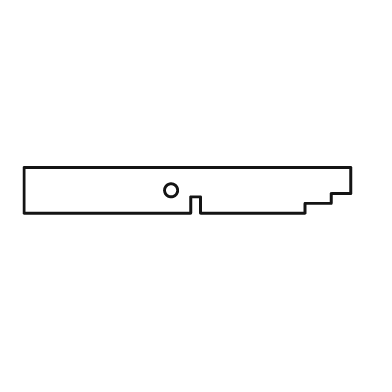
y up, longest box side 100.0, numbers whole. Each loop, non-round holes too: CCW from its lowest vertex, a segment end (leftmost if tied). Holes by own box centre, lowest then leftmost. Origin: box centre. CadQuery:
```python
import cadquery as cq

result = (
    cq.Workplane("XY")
    .moveTo(-50.0, -7.0)
    .lineTo(1.0, -7.0)
    .lineTo(1.0, -2.0)
    .lineTo(4.0, -2.0)
    .lineTo(4.0, -7.0)
    .lineTo(36.0, -7.0)
    .lineTo(36.0, -4.0)
    .lineTo(44.0, -4.0)
    .lineTo(44.0, -1.0)
    .lineTo(50.0, -1.0)
    .lineTo(50.0, 7.0)
    .lineTo(-50.0, 7.0)
    .close()
    .moveTo(-5.0, 0.0)
    .circle(2.0)
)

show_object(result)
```